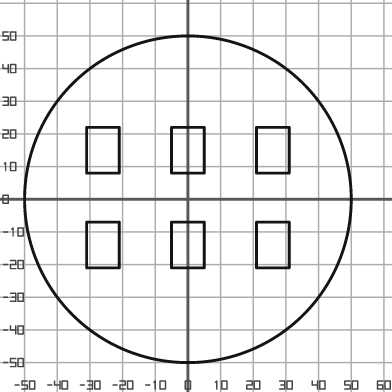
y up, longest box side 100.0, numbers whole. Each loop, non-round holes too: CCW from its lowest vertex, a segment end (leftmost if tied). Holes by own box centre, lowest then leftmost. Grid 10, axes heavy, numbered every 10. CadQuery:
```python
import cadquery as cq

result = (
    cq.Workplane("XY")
    .moveTo(0.0, 0.0)
    .circle(50.0)
    .moveTo(-31.0, -21.0)
    .lineTo(-21.0, -21.0)
    .lineTo(-21.0, -7.0)
    .lineTo(-31.0, -7.0)
    .close()
    .moveTo(-5.0, -21.0)
    .lineTo(5.0, -21.0)
    .lineTo(5.0, -7.0)
    .lineTo(-5.0, -7.0)
    .close()
    .moveTo(21.0, -21.0)
    .lineTo(31.0, -21.0)
    .lineTo(31.0, -7.0)
    .lineTo(21.0, -7.0)
    .close()
    .moveTo(-31.0, 8.0)
    .lineTo(-21.0, 8.0)
    .lineTo(-21.0, 22.0)
    .lineTo(-31.0, 22.0)
    .close()
    .moveTo(-5.0, 8.0)
    .lineTo(5.0, 8.0)
    .lineTo(5.0, 22.0)
    .lineTo(-5.0, 22.0)
    .close()
    .moveTo(21.0, 8.0)
    .lineTo(31.0, 8.0)
    .lineTo(31.0, 22.0)
    .lineTo(21.0, 22.0)
    .close()
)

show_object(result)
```